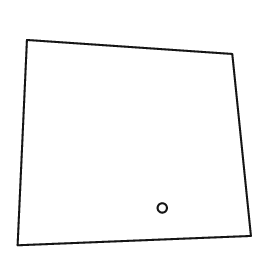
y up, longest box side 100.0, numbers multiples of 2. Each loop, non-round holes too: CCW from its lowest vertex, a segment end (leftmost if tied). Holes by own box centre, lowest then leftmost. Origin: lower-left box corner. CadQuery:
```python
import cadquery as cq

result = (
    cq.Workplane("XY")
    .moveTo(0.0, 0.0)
    .lineTo(100.0, 4.0)
    .lineTo(92.0, 82.0)
    .lineTo(4.0, 88.0)
    .close()
    .moveTo(62.0, 16.0)
    .circle(2.0)
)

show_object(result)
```